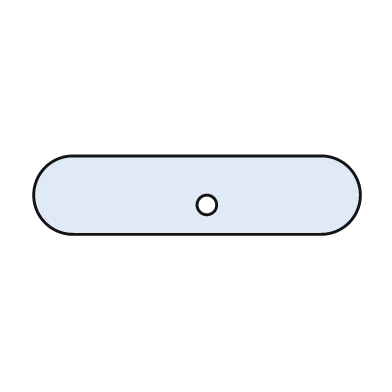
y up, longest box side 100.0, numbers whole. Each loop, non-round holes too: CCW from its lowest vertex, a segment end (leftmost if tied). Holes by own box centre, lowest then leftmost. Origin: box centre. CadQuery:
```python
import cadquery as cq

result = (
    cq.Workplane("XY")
    .moveTo(-38.0, -12.0)
    .lineTo(38.0, -12.0)
    .threePointArc((50.0, 0.0), (38.0, 12.0))
    .lineTo(-38.0, 12.0)
    .threePointArc((-50.0, 0.0), (-38.0, -12.0))
    .close()
    .moveTo(3.0, -3.0)
    .circle(3.0)
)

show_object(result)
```